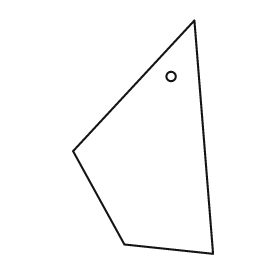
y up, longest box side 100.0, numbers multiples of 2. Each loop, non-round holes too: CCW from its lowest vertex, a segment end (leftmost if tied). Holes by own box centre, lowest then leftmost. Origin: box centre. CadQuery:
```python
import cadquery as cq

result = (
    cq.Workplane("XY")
    .moveTo(30.0, -50.0)
    .lineTo(22.0, 50.0)
    .lineTo(-30.0, -6.0)
    .lineTo(-8.0, -46.0)
    .close()
    .moveTo(12.0, 26.0)
    .circle(2.0)
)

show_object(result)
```